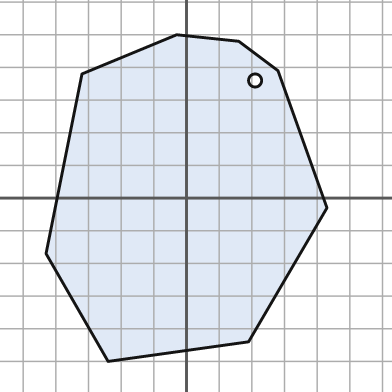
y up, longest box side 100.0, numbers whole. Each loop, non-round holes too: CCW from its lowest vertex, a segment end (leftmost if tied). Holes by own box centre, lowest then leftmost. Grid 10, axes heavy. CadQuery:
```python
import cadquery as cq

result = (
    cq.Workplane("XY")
    .moveTo(-24.0, -50.0)
    .lineTo(19.0, -44.0)
    .lineTo(43.0, -3.0)
    .lineTo(28.0, 39.0)
    .lineTo(16.0, 48.0)
    .lineTo(-3.0, 50.0)
    .lineTo(-32.0, 38.0)
    .lineTo(-43.0, -17.0)
    .close()
    .moveTo(21.0, 36.0)
    .circle(2.0)
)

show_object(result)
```